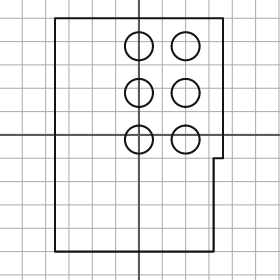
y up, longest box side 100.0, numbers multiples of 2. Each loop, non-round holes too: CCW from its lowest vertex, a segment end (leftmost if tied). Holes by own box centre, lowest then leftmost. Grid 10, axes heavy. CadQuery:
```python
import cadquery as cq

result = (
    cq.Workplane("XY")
    .moveTo(-36.0, -50.0)
    .lineTo(32.0, -50.0)
    .lineTo(32.0, -10.0)
    .lineTo(36.0, -10.0)
    .lineTo(36.0, 50.0)
    .lineTo(-36.0, 50.0)
    .close()
    .moveTo(0.0, -2.0)
    .circle(6.0)
    .moveTo(20.0, -2.0)
    .circle(6.0)
    .moveTo(0.0, 18.0)
    .circle(6.0)
    .moveTo(20.0, 18.0)
    .circle(6.0)
    .moveTo(0.0, 38.0)
    .circle(6.0)
    .moveTo(20.0, 38.0)
    .circle(6.0)
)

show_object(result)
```